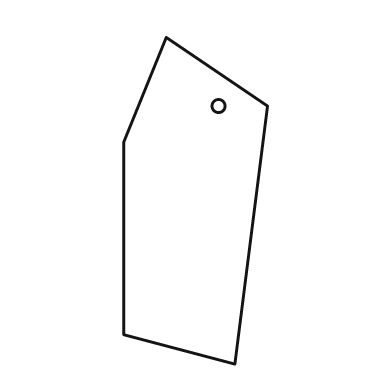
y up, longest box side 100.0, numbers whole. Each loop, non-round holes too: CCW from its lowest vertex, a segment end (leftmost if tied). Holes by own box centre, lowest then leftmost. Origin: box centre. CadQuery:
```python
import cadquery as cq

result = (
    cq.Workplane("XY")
    .moveTo(12.0, -50.0)
    .lineTo(22.0, 29.0)
    .lineTo(-9.0, 50.0)
    .lineTo(-22.0, 18.0)
    .lineTo(-22.0, -41.0)
    .close()
    .moveTo(7.0, 29.0)
    .circle(2.0)
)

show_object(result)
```